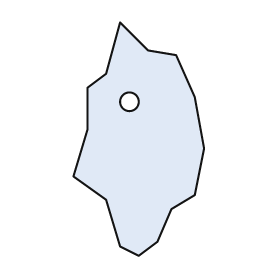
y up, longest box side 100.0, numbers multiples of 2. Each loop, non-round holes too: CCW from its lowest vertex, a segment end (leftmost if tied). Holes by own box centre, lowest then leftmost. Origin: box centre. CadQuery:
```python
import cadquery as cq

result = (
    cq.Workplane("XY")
    .moveTo(0.0, -50.0)
    .lineTo(8.0, -44.0)
    .lineTo(14.0, -30.0)
    .lineTo(24.0, -24.0)
    .lineTo(28.0, -4.0)
    .lineTo(24.0, 18.0)
    .lineTo(16.0, 36.0)
    .lineTo(4.0, 38.0)
    .lineTo(-8.0, 50.0)
    .lineTo(-14.0, 28.0)
    .lineTo(-22.0, 22.0)
    .lineTo(-22.0, 4.0)
    .lineTo(-28.0, -16.0)
    .lineTo(-14.0, -26.0)
    .lineTo(-8.0, -46.0)
    .close()
    .moveTo(-4.0, 16.0)
    .circle(4.0)
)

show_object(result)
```